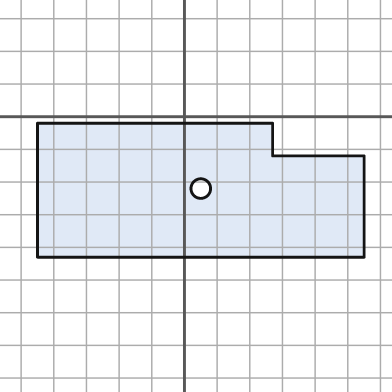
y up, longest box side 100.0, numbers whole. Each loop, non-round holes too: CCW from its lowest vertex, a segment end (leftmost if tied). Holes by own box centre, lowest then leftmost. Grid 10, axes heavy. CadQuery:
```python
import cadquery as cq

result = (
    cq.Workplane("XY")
    .moveTo(-45.0, -43.0)
    .lineTo(55.0, -43.0)
    .lineTo(55.0, -12.0)
    .lineTo(27.0, -12.0)
    .lineTo(27.0, -2.0)
    .lineTo(-45.0, -2.0)
    .close()
    .moveTo(5.0, -22.0)
    .circle(3.0)
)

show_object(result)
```